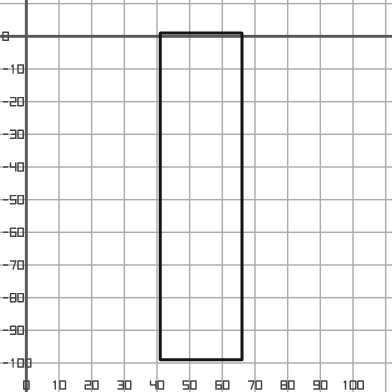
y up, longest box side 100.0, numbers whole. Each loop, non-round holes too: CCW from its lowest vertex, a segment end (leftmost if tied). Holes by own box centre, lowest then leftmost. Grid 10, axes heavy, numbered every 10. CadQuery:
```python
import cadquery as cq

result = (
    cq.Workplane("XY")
    .moveTo(41.0, -99.0)
    .lineTo(66.0, -99.0)
    .lineTo(66.0, 1.0)
    .lineTo(41.0, 1.0)
    .close()
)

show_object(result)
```